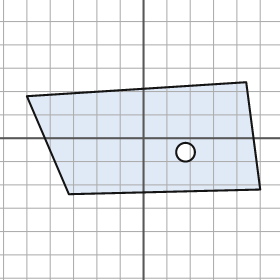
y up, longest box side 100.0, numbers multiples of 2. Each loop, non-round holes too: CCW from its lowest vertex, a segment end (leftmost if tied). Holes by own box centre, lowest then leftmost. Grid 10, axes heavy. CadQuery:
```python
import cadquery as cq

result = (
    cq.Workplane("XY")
    .moveTo(-32.0, -24.0)
    .lineTo(50.0, -22.0)
    .lineTo(44.0, 24.0)
    .lineTo(-50.0, 18.0)
    .close()
    .moveTo(18.0, -6.0)
    .circle(4.0)
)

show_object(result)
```